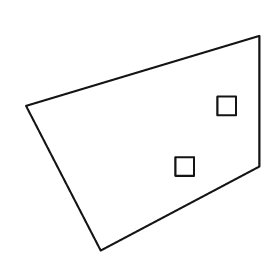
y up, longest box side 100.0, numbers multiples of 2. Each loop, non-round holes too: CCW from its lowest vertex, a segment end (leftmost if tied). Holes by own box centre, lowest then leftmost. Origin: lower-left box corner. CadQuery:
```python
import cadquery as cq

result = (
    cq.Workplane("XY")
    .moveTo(32.0, 0.0)
    .lineTo(100.0, 36.0)
    .lineTo(100.0, 92.0)
    .lineTo(0.0, 62.0)
    .close()
    .moveTo(64.0, 32.0)
    .lineTo(72.0, 32.0)
    .lineTo(72.0, 40.0)
    .lineTo(64.0, 40.0)
    .close()
    .moveTo(82.0, 58.0)
    .lineTo(90.0, 58.0)
    .lineTo(90.0, 66.0)
    .lineTo(82.0, 66.0)
    .close()
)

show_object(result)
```